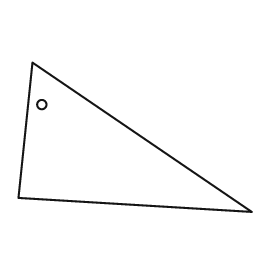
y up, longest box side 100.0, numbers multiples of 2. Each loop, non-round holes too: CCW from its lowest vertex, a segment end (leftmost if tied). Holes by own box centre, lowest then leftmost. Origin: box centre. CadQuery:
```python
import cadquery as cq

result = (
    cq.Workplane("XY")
    .moveTo(50.0, -32.0)
    .lineTo(-44.0, 32.0)
    .lineTo(-50.0, -26.0)
    .close()
    .moveTo(-40.0, 14.0)
    .circle(2.0)
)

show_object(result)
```